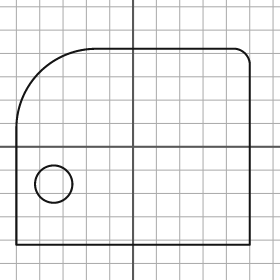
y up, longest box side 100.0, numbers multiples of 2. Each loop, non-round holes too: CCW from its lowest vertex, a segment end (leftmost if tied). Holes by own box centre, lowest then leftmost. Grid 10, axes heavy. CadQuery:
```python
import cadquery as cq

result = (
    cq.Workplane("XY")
    .moveTo(-50.0, -42.0)
    .lineTo(50.0, -42.0)
    .lineTo(50.0, 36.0)
    .threePointArc((48.0, 40.0), (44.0, 42.0))
    .lineTo(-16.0, 42.0)
    .threePointArc((-40.0, 32.0), (-50.0, 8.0))
    .close()
    .moveTo(-34.0, -16.0)
    .circle(8.0)
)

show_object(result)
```